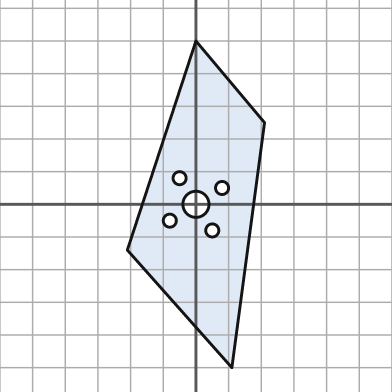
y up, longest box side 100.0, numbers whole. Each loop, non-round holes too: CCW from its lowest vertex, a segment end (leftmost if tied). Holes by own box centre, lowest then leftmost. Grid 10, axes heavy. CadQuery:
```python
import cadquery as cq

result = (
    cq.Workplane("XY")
    .moveTo(11.0, -50.0)
    .lineTo(21.0, 25.0)
    .lineTo(0.0, 50.0)
    .lineTo(-21.0, -14.0)
    .close()
    .moveTo(5.0, -8.0)
    .circle(2.0)
    .moveTo(-8.0, -5.0)
    .circle(2.0)
    .moveTo(0.0, 0.0)
    .circle(4.0)
    .moveTo(8.0, 5.0)
    .circle(2.0)
    .moveTo(-5.0, 8.0)
    .circle(2.0)
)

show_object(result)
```